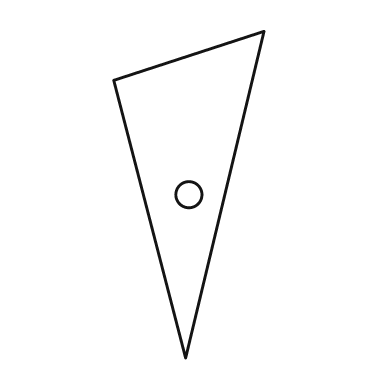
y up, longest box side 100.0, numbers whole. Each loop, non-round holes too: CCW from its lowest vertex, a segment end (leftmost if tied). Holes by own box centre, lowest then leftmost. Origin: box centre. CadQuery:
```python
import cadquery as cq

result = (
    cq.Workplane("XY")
    .moveTo(-1.0, -50.0)
    .lineTo(23.0, 50.0)
    .lineTo(-23.0, 35.0)
    .close()
    .moveTo(0.0, 0.0)
    .circle(4.0)
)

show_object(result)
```